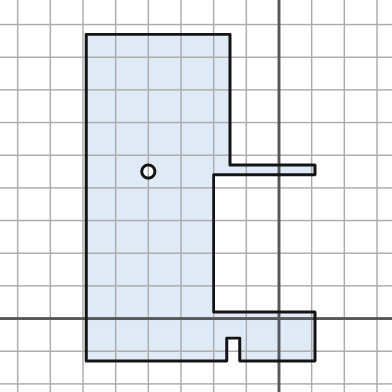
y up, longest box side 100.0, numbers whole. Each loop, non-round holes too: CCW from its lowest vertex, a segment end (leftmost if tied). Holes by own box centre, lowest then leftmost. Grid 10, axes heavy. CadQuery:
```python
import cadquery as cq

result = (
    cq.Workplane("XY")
    .moveTo(-59.0, -13.0)
    .lineTo(-16.0, -13.0)
    .lineTo(-16.0, -6.0)
    .lineTo(-12.0, -6.0)
    .lineTo(-12.0, -13.0)
    .lineTo(11.0, -13.0)
    .lineTo(11.0, 2.0)
    .lineTo(-20.0, 2.0)
    .lineTo(-20.0, 44.0)
    .lineTo(11.0, 44.0)
    .lineTo(11.0, 47.0)
    .lineTo(-15.0, 47.0)
    .lineTo(-15.0, 87.0)
    .lineTo(-59.0, 87.0)
    .close()
    .moveTo(-40.0, 45.0)
    .circle(2.0)
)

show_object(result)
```